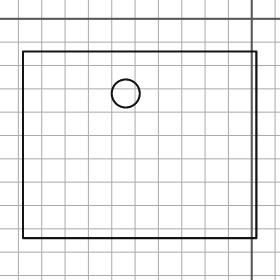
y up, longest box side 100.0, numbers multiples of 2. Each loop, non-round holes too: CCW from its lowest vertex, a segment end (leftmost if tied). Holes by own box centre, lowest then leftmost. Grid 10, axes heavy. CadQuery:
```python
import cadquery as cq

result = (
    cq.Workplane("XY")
    .moveTo(-98.0, -94.0)
    .lineTo(2.0, -94.0)
    .lineTo(2.0, -14.0)
    .lineTo(-98.0, -14.0)
    .close()
    .moveTo(-54.0, -32.0)
    .circle(6.0)
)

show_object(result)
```